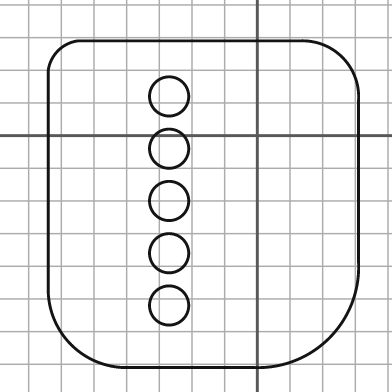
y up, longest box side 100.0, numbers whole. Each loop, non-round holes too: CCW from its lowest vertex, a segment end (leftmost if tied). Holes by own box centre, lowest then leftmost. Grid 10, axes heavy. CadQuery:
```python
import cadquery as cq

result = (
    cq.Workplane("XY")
    .moveTo(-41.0, -71.0)
    .lineTo(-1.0, -71.0)
    .threePointArc((22.0, -62.0), (31.0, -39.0))
    .lineTo(31.0, 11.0)
    .threePointArc((26.0, 24.0), (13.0, 29.0))
    .lineTo(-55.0, 29.0)
    .threePointArc((-61.0, 26.0), (-64.0, 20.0))
    .lineTo(-64.0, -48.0)
    .threePointArc((-57.0, -64.0), (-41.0, -71.0))
    .close()
    .moveTo(-27.0, -52.0)
    .circle(6.0)
    .moveTo(-27.0, -36.0)
    .circle(6.0)
    .moveTo(-27.0, -20.0)
    .circle(6.0)
    .moveTo(-27.0, -4.0)
    .circle(6.0)
    .moveTo(-27.0, 12.0)
    .circle(6.0)
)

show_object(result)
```